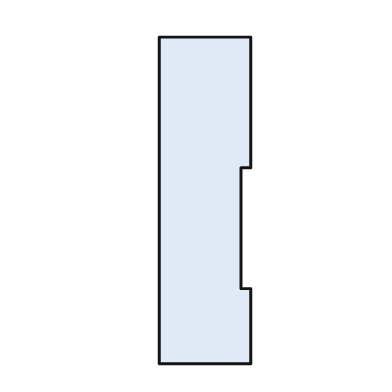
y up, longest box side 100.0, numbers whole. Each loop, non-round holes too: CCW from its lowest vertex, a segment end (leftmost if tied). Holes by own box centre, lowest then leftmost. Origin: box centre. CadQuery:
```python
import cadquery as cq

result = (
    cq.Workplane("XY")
    .moveTo(-14.0, -50.0)
    .lineTo(14.0, -50.0)
    .lineTo(14.0, -27.0)
    .lineTo(11.0, -27.0)
    .lineTo(11.0, 10.0)
    .lineTo(14.0, 10.0)
    .lineTo(14.0, 50.0)
    .lineTo(-14.0, 50.0)
    .close()
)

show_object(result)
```